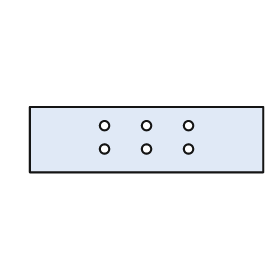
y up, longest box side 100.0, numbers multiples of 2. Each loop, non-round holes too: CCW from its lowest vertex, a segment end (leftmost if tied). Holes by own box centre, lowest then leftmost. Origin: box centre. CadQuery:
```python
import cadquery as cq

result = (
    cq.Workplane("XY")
    .moveTo(-50.0, -14.0)
    .lineTo(50.0, -14.0)
    .lineTo(50.0, 14.0)
    .lineTo(-50.0, 14.0)
    .close()
    .moveTo(-18.0, -4.0)
    .circle(2.0)
    .moveTo(0.0, -4.0)
    .circle(2.0)
    .moveTo(18.0, -4.0)
    .circle(2.0)
    .moveTo(-18.0, 6.0)
    .circle(2.0)
    .moveTo(0.0, 6.0)
    .circle(2.0)
    .moveTo(18.0, 6.0)
    .circle(2.0)
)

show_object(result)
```